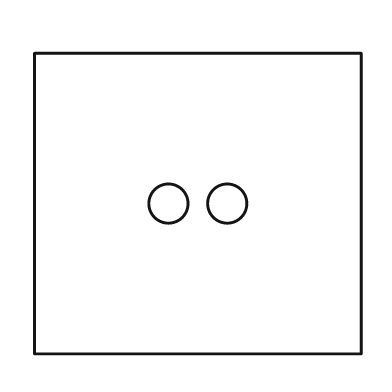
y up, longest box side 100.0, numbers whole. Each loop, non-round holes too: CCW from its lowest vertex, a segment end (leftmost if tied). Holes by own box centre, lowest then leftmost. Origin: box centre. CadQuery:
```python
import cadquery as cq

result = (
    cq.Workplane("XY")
    .moveTo(-50.0, -46.0)
    .lineTo(50.0, -46.0)
    .lineTo(50.0, 46.0)
    .lineTo(-50.0, 46.0)
    .close()
    .moveTo(-9.0, 0.0)
    .circle(6.0)
    .moveTo(9.0, 0.0)
    .circle(6.0)
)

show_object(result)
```